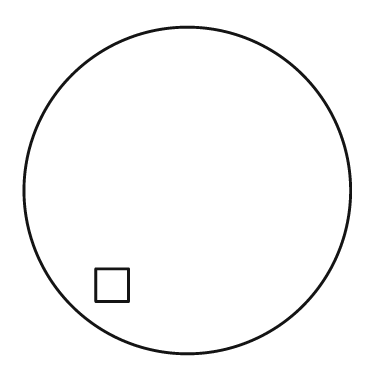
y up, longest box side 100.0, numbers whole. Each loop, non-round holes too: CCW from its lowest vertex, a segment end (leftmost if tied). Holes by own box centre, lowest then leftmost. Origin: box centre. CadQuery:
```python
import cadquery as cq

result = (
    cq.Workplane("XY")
    .moveTo(0.0, 0.0)
    .circle(50.0)
    .moveTo(-28.0, -34.0)
    .lineTo(-18.0, -34.0)
    .lineTo(-18.0, -24.0)
    .lineTo(-28.0, -24.0)
    .close()
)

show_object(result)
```